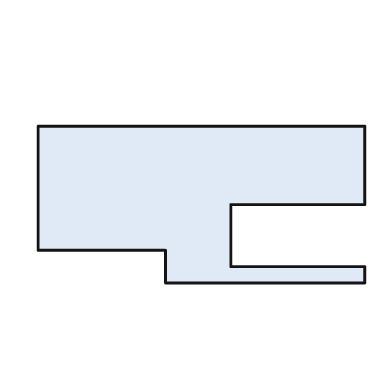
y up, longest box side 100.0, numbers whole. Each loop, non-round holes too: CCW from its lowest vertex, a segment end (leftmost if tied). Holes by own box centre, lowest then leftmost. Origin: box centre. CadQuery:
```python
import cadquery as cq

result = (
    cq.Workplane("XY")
    .moveTo(-11.0, -24.0)
    .lineTo(50.0, -24.0)
    .lineTo(50.0, -19.0)
    .lineTo(9.0, -19.0)
    .lineTo(9.0, 0.0)
    .lineTo(50.0, 0.0)
    .lineTo(50.0, 24.0)
    .lineTo(-50.0, 24.0)
    .lineTo(-50.0, -14.0)
    .lineTo(-11.0, -14.0)
    .close()
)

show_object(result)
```